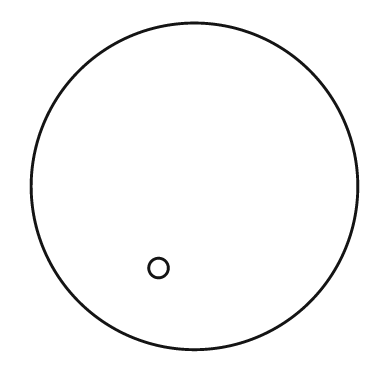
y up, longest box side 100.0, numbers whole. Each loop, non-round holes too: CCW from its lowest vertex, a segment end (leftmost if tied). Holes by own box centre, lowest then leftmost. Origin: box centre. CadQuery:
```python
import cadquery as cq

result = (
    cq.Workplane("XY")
    .moveTo(0.0, 0.0)
    .circle(50.0)
    .moveTo(-11.0, -25.0)
    .circle(3.0)
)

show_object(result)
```